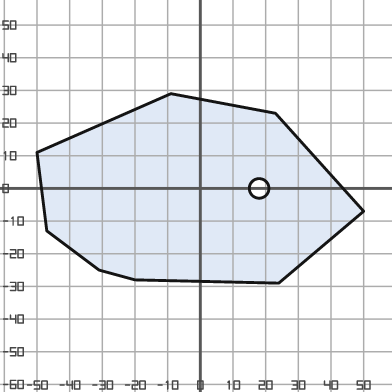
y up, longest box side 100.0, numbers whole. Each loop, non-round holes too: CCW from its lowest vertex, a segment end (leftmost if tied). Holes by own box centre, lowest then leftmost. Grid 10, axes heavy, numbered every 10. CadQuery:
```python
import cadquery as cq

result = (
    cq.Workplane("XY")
    .moveTo(24.0, -29.0)
    .lineTo(50.0, -7.0)
    .lineTo(23.0, 23.0)
    .lineTo(-9.0, 29.0)
    .lineTo(-50.0, 11.0)
    .lineTo(-47.0, -13.0)
    .lineTo(-31.0, -25.0)
    .lineTo(-20.0, -28.0)
    .close()
    .moveTo(18.0, 0.0)
    .circle(3.0)
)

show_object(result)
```